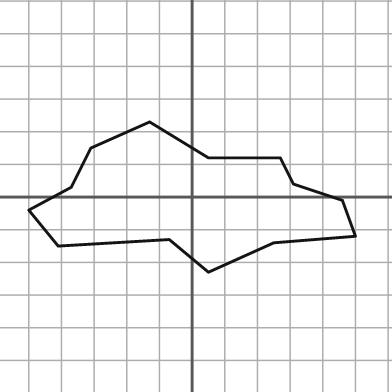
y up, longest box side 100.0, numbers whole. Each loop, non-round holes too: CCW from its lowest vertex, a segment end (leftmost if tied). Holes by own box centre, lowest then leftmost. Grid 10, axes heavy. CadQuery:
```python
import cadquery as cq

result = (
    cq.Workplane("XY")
    .moveTo(5.0, -23.0)
    .lineTo(25.0, -14.0)
    .lineTo(50.0, -12.0)
    .lineTo(46.0, -1.0)
    .lineTo(31.0, 4.0)
    .lineTo(27.0, 12.0)
    .lineTo(5.0, 12.0)
    .lineTo(-13.0, 23.0)
    .lineTo(-31.0, 15.0)
    .lineTo(-37.0, 3.0)
    .lineTo(-50.0, -4.0)
    .lineTo(-41.0, -15.0)
    .lineTo(-7.0, -13.0)
    .close()
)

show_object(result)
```